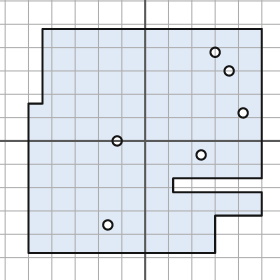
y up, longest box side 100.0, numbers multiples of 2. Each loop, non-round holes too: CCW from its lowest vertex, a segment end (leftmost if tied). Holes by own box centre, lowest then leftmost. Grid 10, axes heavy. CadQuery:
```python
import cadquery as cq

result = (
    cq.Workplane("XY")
    .moveTo(-50.0, -48.0)
    .lineTo(30.0, -48.0)
    .lineTo(30.0, -32.0)
    .lineTo(50.0, -32.0)
    .lineTo(50.0, -22.0)
    .lineTo(12.0, -22.0)
    .lineTo(12.0, -16.0)
    .lineTo(50.0, -16.0)
    .lineTo(50.0, 48.0)
    .lineTo(-44.0, 48.0)
    .lineTo(-44.0, 16.0)
    .lineTo(-50.0, 16.0)
    .close()
    .moveTo(-16.0, -36.0)
    .circle(2.0)
    .moveTo(24.0, -6.0)
    .circle(2.0)
    .moveTo(-12.0, 0.0)
    .circle(2.0)
    .moveTo(42.0, 12.0)
    .circle(2.0)
    .moveTo(36.0, 30.0)
    .circle(2.0)
    .moveTo(30.0, 38.0)
    .circle(2.0)
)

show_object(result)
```